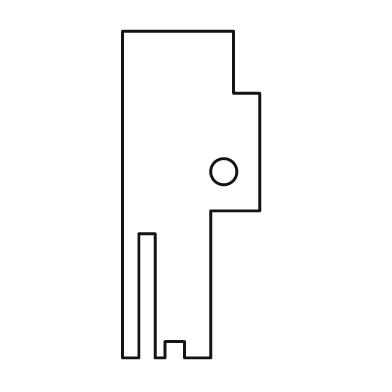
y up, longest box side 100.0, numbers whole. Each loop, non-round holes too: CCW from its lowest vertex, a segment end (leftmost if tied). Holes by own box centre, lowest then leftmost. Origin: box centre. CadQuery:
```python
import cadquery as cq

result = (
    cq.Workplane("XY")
    .moveTo(-21.0, -50.0)
    .lineTo(-16.0, -50.0)
    .lineTo(-16.0, -12.0)
    .lineTo(-11.0, -12.0)
    .lineTo(-11.0, -50.0)
    .lineTo(-8.0, -50.0)
    .lineTo(-8.0, -45.0)
    .lineTo(-2.0, -45.0)
    .lineTo(-2.0, -50.0)
    .lineTo(6.0, -50.0)
    .lineTo(6.0, -5.0)
    .lineTo(21.0, -5.0)
    .lineTo(21.0, 31.0)
    .lineTo(13.0, 31.0)
    .lineTo(13.0, 50.0)
    .lineTo(-21.0, 50.0)
    .close()
    .moveTo(10.0, 7.0)
    .circle(4.0)
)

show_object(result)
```